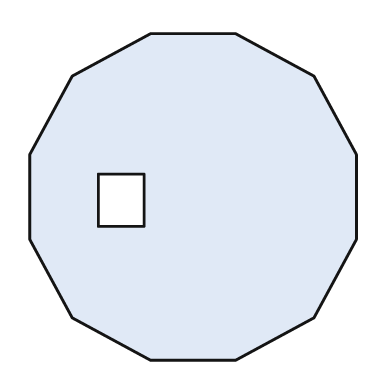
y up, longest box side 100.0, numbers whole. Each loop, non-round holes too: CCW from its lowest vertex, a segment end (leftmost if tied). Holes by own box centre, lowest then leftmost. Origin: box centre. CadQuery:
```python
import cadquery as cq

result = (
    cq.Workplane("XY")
    .moveTo(-13.0, -50.0)
    .lineTo(13.0, -50.0)
    .lineTo(37.0, -37.0)
    .lineTo(50.0, -13.0)
    .lineTo(50.0, 13.0)
    .lineTo(37.0, 37.0)
    .lineTo(13.0, 50.0)
    .lineTo(-13.0, 50.0)
    .lineTo(-37.0, 37.0)
    .lineTo(-50.0, 13.0)
    .lineTo(-50.0, -13.0)
    .lineTo(-37.0, -37.0)
    .close()
    .moveTo(-29.0, -9.0)
    .lineTo(-15.0, -9.0)
    .lineTo(-15.0, 7.0)
    .lineTo(-29.0, 7.0)
    .close()
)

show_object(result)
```